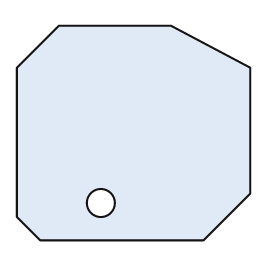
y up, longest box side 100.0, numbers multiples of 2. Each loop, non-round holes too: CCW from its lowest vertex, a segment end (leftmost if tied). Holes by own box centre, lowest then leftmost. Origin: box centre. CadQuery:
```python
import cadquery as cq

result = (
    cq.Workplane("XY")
    .moveTo(-40.0, -46.0)
    .lineTo(30.0, -46.0)
    .lineTo(50.0, -26.0)
    .lineTo(50.0, 28.0)
    .lineTo(16.0, 46.0)
    .lineTo(-32.0, 46.0)
    .lineTo(-50.0, 28.0)
    .lineTo(-50.0, -36.0)
    .close()
    .moveTo(-14.0, -30.0)
    .circle(6.0)
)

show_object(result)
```